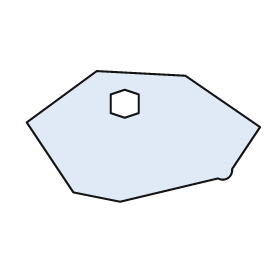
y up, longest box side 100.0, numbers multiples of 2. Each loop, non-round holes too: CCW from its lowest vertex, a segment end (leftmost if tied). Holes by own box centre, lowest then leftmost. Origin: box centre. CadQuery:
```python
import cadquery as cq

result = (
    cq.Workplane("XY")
    .moveTo(-10.0, -28.0)
    .lineTo(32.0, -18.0)
    .threePointArc((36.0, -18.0), (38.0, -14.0))
    .lineTo(50.0, 4.0)
    .lineTo(18.0, 26.0)
    .lineTo(-20.0, 28.0)
    .lineTo(-50.0, 6.0)
    .lineTo(-30.0, -24.0)
    .close()
    .moveTo(-8.0, 8.0)
    .lineTo(-2.0, 10.0)
    .lineTo(-2.0, 18.0)
    .lineTo(-8.0, 20.0)
    .lineTo(-14.0, 18.0)
    .lineTo(-14.0, 10.0)
    .close()
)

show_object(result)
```